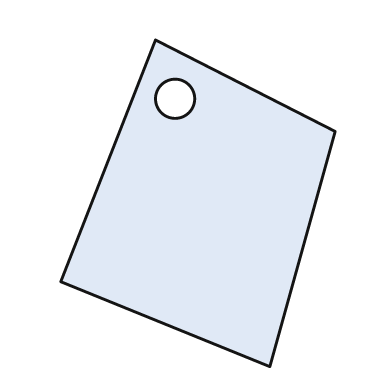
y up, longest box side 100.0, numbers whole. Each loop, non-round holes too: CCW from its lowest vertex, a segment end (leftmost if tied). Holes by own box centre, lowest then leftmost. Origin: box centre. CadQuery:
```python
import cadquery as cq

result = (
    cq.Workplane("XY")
    .moveTo(22.0, -50.0)
    .lineTo(42.0, 22.0)
    .lineTo(-13.0, 50.0)
    .lineTo(-42.0, -24.0)
    .close()
    .moveTo(-7.0, 32.0)
    .circle(6.0)
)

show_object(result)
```